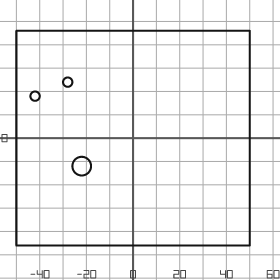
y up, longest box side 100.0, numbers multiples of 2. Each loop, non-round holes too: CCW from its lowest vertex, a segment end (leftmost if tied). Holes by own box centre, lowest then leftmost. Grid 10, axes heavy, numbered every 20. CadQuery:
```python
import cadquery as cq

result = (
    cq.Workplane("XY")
    .moveTo(-50.0, -46.0)
    .lineTo(50.0, -46.0)
    .lineTo(50.0, 46.0)
    .lineTo(-50.0, 46.0)
    .close()
    .moveTo(-22.0, -12.0)
    .circle(4.0)
    .moveTo(-42.0, 18.0)
    .circle(2.0)
    .moveTo(-28.0, 24.0)
    .circle(2.0)
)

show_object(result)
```